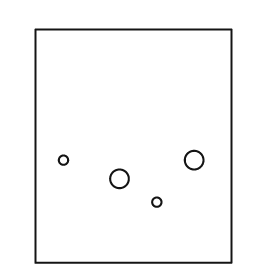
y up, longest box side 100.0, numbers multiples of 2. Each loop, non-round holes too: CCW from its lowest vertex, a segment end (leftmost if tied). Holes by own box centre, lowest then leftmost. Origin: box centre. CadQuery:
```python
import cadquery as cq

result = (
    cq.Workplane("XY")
    .moveTo(-42.0, -50.0)
    .lineTo(42.0, -50.0)
    .lineTo(42.0, 50.0)
    .lineTo(-42.0, 50.0)
    .close()
    .moveTo(10.0, -24.0)
    .circle(2.0)
    .moveTo(-6.0, -14.0)
    .circle(4.0)
    .moveTo(-30.0, -6.0)
    .circle(2.0)
    .moveTo(26.0, -6.0)
    .circle(4.0)
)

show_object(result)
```